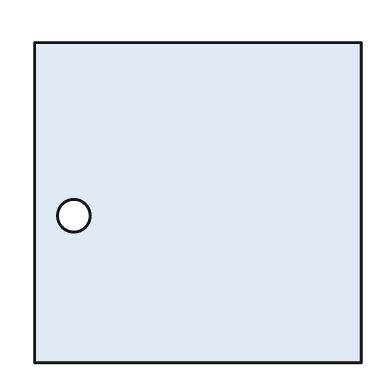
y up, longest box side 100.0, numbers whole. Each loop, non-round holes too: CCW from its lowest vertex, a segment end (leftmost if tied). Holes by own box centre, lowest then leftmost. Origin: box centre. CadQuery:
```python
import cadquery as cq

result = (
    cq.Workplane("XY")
    .moveTo(-50.0, -49.0)
    .lineTo(50.0, -49.0)
    .lineTo(50.0, 49.0)
    .lineTo(-50.0, 49.0)
    .close()
    .moveTo(-38.0, -4.0)
    .circle(5.0)
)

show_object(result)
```